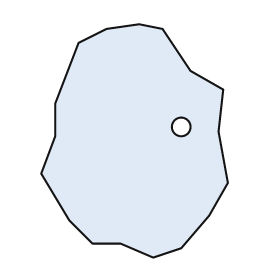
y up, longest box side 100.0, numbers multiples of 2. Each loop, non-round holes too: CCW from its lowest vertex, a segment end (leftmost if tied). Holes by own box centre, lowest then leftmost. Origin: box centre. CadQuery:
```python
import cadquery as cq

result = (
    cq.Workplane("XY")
    .moveTo(8.0, -50.0)
    .lineTo(20.0, -46.0)
    .lineTo(32.0, -32.0)
    .lineTo(40.0, -18.0)
    .lineTo(36.0, 4.0)
    .lineTo(38.0, 22.0)
    .lineTo(24.0, 30.0)
    .lineTo(12.0, 48.0)
    .lineTo(2.0, 50.0)
    .lineTo(-12.0, 48.0)
    .lineTo(-24.0, 42.0)
    .lineTo(-34.0, 16.0)
    .lineTo(-34.0, 2.0)
    .lineTo(-40.0, -14.0)
    .lineTo(-28.0, -34.0)
    .lineTo(-18.0, -44.0)
    .lineTo(-6.0, -44.0)
    .close()
    .moveTo(20.0, 6.0)
    .circle(4.0)
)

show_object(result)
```